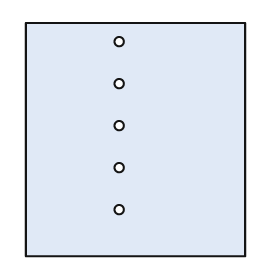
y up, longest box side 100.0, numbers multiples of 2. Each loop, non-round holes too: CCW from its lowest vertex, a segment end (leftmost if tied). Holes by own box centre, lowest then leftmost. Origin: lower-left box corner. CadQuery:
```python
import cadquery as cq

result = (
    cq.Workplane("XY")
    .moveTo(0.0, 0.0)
    .lineTo(94.0, 0.0)
    .lineTo(94.0, 100.0)
    .lineTo(0.0, 100.0)
    .close()
    .moveTo(40.0, 20.0)
    .circle(2.0)
    .moveTo(40.0, 38.0)
    .circle(2.0)
    .moveTo(40.0, 56.0)
    .circle(2.0)
    .moveTo(40.0, 74.0)
    .circle(2.0)
    .moveTo(40.0, 92.0)
    .circle(2.0)
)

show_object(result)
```